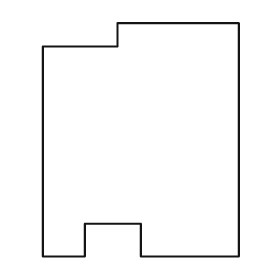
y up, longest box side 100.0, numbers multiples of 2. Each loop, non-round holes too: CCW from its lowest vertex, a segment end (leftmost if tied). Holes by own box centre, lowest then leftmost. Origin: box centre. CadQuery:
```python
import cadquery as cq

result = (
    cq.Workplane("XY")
    .moveTo(-42.0, -50.0)
    .lineTo(-24.0, -50.0)
    .lineTo(-24.0, -36.0)
    .lineTo(0.0, -36.0)
    .lineTo(0.0, -50.0)
    .lineTo(42.0, -50.0)
    .lineTo(42.0, 50.0)
    .lineTo(-10.0, 50.0)
    .lineTo(-10.0, 40.0)
    .lineTo(-42.0, 40.0)
    .close()
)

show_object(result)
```